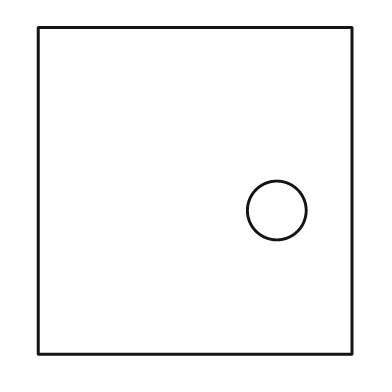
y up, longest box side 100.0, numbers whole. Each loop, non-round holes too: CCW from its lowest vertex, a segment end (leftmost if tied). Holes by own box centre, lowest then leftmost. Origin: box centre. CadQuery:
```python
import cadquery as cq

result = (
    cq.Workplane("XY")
    .moveTo(-48.0, -50.0)
    .lineTo(48.0, -50.0)
    .lineTo(48.0, 50.0)
    .lineTo(-48.0, 50.0)
    .close()
    .moveTo(25.0, -6.0)
    .circle(9.0)
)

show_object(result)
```